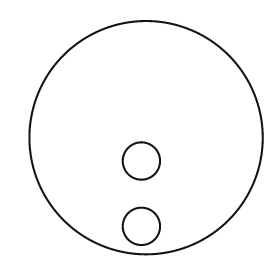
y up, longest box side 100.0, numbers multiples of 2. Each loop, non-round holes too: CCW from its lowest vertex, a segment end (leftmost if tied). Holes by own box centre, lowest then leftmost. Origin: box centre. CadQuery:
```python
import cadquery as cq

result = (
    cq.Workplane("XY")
    .moveTo(0.0, 0.0)
    .circle(50.0)
    .moveTo(-2.0, -38.0)
    .circle(8.0)
    .moveTo(-2.0, -10.0)
    .circle(8.0)
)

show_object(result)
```